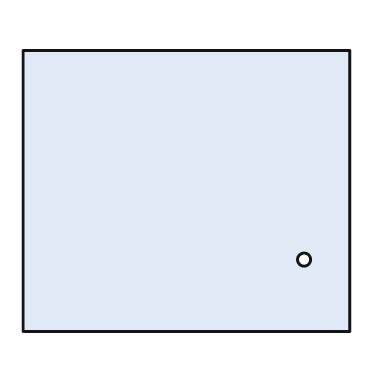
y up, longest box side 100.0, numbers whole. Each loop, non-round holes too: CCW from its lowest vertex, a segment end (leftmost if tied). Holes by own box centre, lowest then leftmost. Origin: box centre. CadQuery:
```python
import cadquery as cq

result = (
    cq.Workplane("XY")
    .moveTo(-50.0, -43.0)
    .lineTo(50.0, -43.0)
    .lineTo(50.0, 43.0)
    .lineTo(-50.0, 43.0)
    .close()
    .moveTo(36.0, -21.0)
    .circle(2.0)
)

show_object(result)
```